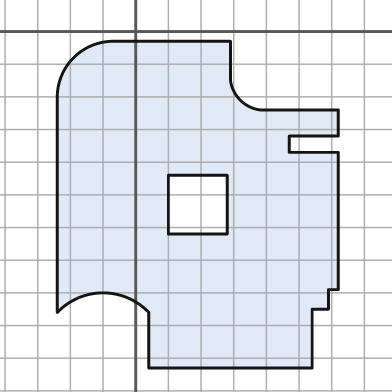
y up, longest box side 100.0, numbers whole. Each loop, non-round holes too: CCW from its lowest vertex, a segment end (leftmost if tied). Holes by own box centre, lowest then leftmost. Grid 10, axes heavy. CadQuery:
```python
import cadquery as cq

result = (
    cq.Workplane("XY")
    .moveTo(4.0, -103.0)
    .lineTo(54.0, -103.0)
    .lineTo(54.0, -85.0)
    .lineTo(59.0, -85.0)
    .lineTo(59.0, -79.0)
    .lineTo(62.0, -79.0)
    .lineTo(62.0, -37.0)
    .lineTo(47.0, -37.0)
    .lineTo(47.0, -32.0)
    .lineTo(62.0, -32.0)
    .lineTo(62.0, -24.0)
    .lineTo(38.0, -24.0)
    .threePointArc((32.0, -21.0), (29.0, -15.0))
    .lineTo(29.0, -3.0)
    .lineTo(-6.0, -3.0)
    .threePointArc((-19.0, -8.0), (-24.0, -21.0))
    .lineTo(-24.0, -86.0)
    .threePointArc((-10.0, -80.0), (4.0, -86.0))
    .close()
    .moveTo(10.0, -62.0)
    .lineTo(28.0, -62.0)
    .lineTo(28.0, -44.0)
    .lineTo(10.0, -44.0)
    .close()
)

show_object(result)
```